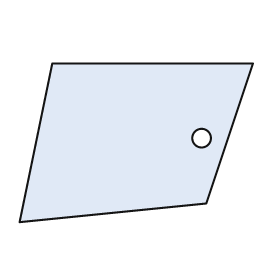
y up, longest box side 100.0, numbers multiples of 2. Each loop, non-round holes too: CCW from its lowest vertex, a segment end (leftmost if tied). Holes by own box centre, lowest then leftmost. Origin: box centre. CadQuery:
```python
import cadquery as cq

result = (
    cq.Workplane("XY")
    .moveTo(-50.0, -34.0)
    .lineTo(30.0, -26.0)
    .lineTo(50.0, 34.0)
    .lineTo(-36.0, 34.0)
    .close()
    .moveTo(28.0, 2.0)
    .circle(4.0)
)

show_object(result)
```